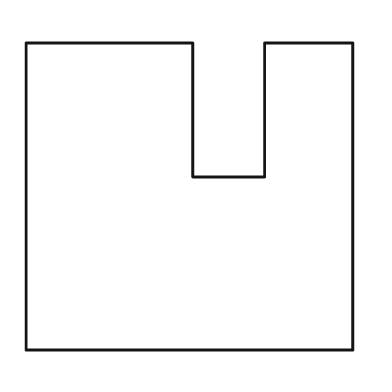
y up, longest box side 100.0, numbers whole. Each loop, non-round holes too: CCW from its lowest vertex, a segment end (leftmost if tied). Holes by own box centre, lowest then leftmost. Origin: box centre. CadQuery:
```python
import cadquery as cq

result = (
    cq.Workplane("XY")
    .moveTo(-50.0, -47.0)
    .lineTo(50.0, -47.0)
    .lineTo(50.0, 47.0)
    .lineTo(23.0, 47.0)
    .lineTo(23.0, 6.0)
    .lineTo(1.0, 6.0)
    .lineTo(1.0, 47.0)
    .lineTo(-50.0, 47.0)
    .close()
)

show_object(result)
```